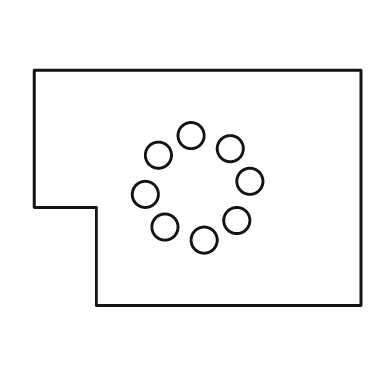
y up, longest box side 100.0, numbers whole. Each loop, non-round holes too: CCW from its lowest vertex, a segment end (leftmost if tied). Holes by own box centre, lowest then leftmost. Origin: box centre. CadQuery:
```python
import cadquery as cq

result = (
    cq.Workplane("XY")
    .moveTo(-31.0, -36.0)
    .lineTo(50.0, -36.0)
    .lineTo(50.0, 36.0)
    .lineTo(-50.0, 36.0)
    .lineTo(-50.0, -6.0)
    .lineTo(-31.0, -6.0)
    .close()
    .moveTo(2.0, -16.0)
    .circle(4.0)
    .moveTo(-10.0, -12.0)
    .circle(4.0)
    .moveTo(12.0, -10.0)
    .circle(4.0)
    .moveTo(-16.0, -2.0)
    .circle(4.0)
    .moveTo(16.0, 2.0)
    .circle(4.0)
    .moveTo(-12.0, 10.0)
    .circle(4.0)
    .moveTo(10.0, 12.0)
    .circle(4.0)
    .moveTo(-2.0, 16.0)
    .circle(4.0)
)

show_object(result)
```